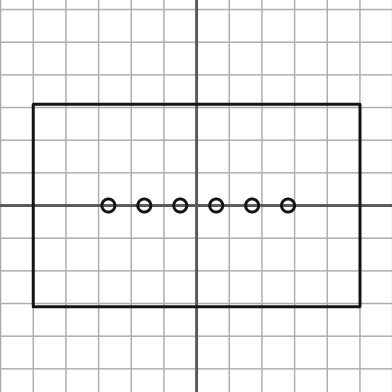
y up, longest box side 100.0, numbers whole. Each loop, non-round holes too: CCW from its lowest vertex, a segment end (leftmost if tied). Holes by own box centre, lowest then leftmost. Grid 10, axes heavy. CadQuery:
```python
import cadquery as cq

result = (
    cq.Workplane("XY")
    .moveTo(-50.0, -31.0)
    .lineTo(50.0, -31.0)
    .lineTo(50.0, 31.0)
    .lineTo(-50.0, 31.0)
    .close()
    .moveTo(-27.0, 0.0)
    .circle(2.0)
    .moveTo(-16.0, 0.0)
    .circle(2.0)
    .moveTo(-5.0, 0.0)
    .circle(2.0)
    .moveTo(6.0, 0.0)
    .circle(2.0)
    .moveTo(17.0, 0.0)
    .circle(2.0)
    .moveTo(28.0, 0.0)
    .circle(2.0)
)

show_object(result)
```